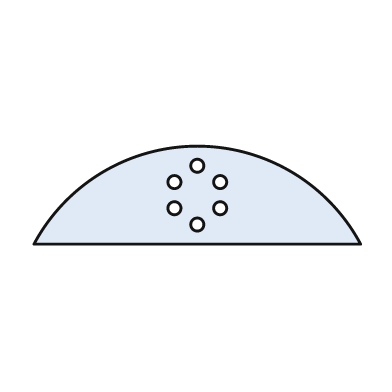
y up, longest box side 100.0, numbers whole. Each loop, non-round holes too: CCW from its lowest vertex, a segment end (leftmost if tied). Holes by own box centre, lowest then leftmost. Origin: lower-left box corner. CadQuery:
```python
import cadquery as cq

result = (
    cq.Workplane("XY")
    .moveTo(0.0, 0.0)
    .lineTo(100.0, 0.0)
    .threePointArc((50.0, 30.0), (0.0, 0.0))
    .close()
    .moveTo(50.0, 6.0)
    .circle(2.0)
    .moveTo(43.0, 11.0)
    .circle(2.0)
    .moveTo(57.0, 11.0)
    .circle(2.0)
    .moveTo(43.0, 19.0)
    .circle(2.0)
    .moveTo(57.0, 19.0)
    .circle(2.0)
    .moveTo(50.0, 24.0)
    .circle(2.0)
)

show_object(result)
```